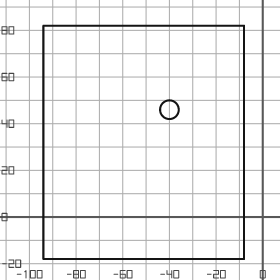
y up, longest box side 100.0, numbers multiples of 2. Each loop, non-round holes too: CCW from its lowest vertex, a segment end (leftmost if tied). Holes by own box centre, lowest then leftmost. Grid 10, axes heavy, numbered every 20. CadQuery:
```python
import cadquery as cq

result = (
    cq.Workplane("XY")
    .moveTo(-94.0, -18.0)
    .lineTo(-8.0, -18.0)
    .lineTo(-8.0, 82.0)
    .lineTo(-94.0, 82.0)
    .close()
    .moveTo(-40.0, 46.0)
    .circle(4.0)
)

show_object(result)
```